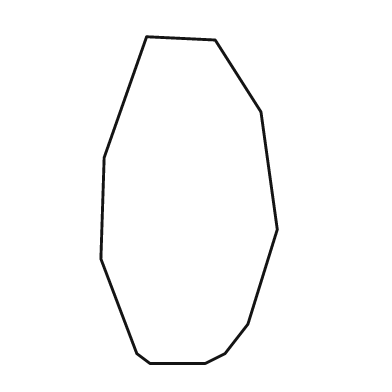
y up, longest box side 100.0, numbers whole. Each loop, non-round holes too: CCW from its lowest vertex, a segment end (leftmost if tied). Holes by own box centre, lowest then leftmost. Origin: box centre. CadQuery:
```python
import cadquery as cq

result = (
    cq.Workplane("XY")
    .moveTo(-12.0, -50.0)
    .lineTo(5.0, -50.0)
    .lineTo(11.0, -47.0)
    .lineTo(18.0, -38.0)
    .lineTo(27.0, -9.0)
    .lineTo(22.0, 27.0)
    .lineTo(8.0, 49.0)
    .lineTo(-13.0, 50.0)
    .lineTo(-26.0, 13.0)
    .lineTo(-27.0, -18.0)
    .lineTo(-16.0, -47.0)
    .close()
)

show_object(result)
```